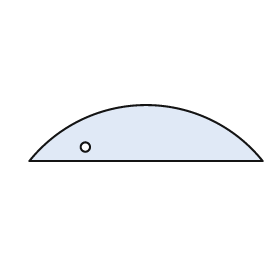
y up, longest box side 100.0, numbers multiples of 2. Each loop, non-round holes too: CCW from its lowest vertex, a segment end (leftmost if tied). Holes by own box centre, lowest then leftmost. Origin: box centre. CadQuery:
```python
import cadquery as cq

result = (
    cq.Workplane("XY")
    .moveTo(-50.0, -12.0)
    .lineTo(50.0, -12.0)
    .threePointArc((0.0, 12.0), (-50.0, -12.0))
    .close()
    .moveTo(-26.0, -6.0)
    .circle(2.0)
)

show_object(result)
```